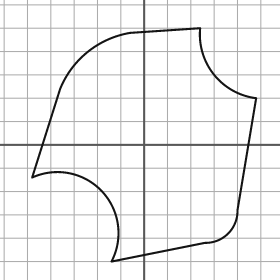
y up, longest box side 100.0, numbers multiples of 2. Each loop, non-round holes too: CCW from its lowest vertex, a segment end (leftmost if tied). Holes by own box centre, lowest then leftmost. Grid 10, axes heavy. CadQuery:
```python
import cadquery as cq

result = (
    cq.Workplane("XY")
    .moveTo(-14.0, -50.0)
    .lineTo(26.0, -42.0)
    .threePointArc((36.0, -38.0), (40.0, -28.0))
    .lineTo(48.0, 20.0)
    .threePointArc((30.0, 30.0), (24.0, 50.0))
    .lineTo(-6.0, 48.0)
    .threePointArc((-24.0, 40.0), (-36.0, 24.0))
    .lineTo(-48.0, -14.0)
    .threePointArc((-18.0, -20.0), (-14.0, -50.0))
    .close()
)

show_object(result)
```